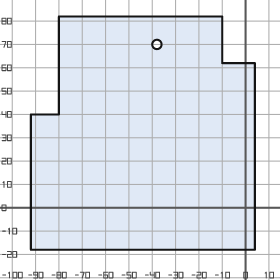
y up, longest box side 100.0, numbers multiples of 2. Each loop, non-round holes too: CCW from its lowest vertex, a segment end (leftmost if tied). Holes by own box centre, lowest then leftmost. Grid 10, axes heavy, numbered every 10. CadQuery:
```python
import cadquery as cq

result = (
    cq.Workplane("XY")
    .moveTo(-92.0, -18.0)
    .lineTo(4.0, -18.0)
    .lineTo(4.0, 62.0)
    .lineTo(-10.0, 62.0)
    .lineTo(-10.0, 82.0)
    .lineTo(-80.0, 82.0)
    .lineTo(-80.0, 40.0)
    .lineTo(-92.0, 40.0)
    .close()
    .moveTo(-38.0, 70.0)
    .circle(2.0)
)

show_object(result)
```